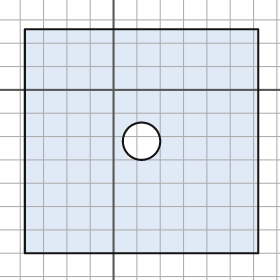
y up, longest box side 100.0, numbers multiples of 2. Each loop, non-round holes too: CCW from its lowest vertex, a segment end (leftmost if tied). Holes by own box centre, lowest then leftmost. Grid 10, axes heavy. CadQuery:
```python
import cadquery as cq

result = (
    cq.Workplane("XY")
    .moveTo(-38.0, -70.0)
    .lineTo(62.0, -70.0)
    .lineTo(62.0, 26.0)
    .lineTo(-38.0, 26.0)
    .close()
    .moveTo(12.0, -22.0)
    .circle(8.0)
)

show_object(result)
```